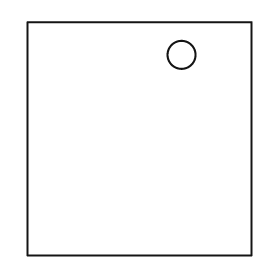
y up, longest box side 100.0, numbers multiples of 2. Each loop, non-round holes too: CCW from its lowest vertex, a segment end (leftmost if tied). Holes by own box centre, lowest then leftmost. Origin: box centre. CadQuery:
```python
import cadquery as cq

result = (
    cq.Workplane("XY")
    .moveTo(-48.0, -50.0)
    .lineTo(48.0, -50.0)
    .lineTo(48.0, 50.0)
    .lineTo(-48.0, 50.0)
    .close()
    .moveTo(18.0, 36.0)
    .circle(6.0)
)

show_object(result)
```